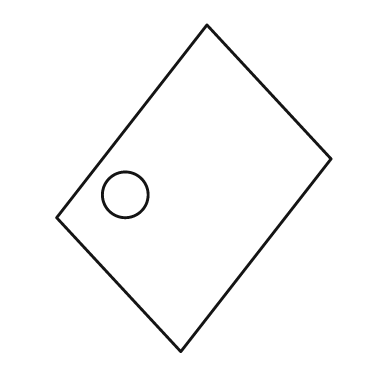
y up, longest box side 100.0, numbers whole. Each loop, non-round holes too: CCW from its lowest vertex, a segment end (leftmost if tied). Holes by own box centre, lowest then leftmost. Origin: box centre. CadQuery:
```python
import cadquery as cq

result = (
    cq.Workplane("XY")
    .moveTo(-4.0, -50.0)
    .lineTo(42.0, 9.0)
    .lineTo(4.0, 50.0)
    .lineTo(-42.0, -9.0)
    .close()
    .moveTo(-21.0, -2.0)
    .circle(7.0)
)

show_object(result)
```